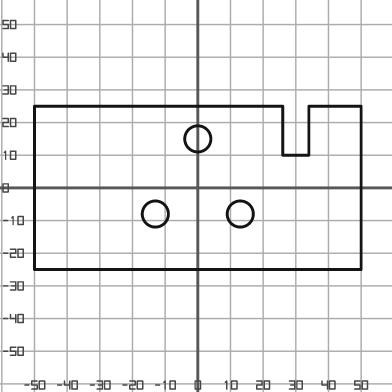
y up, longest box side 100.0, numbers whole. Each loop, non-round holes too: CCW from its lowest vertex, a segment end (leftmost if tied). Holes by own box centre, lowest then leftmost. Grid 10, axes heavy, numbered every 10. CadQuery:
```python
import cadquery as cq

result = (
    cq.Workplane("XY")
    .moveTo(-50.0, -25.0)
    .lineTo(50.0, -25.0)
    .lineTo(50.0, 25.0)
    .lineTo(34.0, 25.0)
    .lineTo(34.0, 10.0)
    .lineTo(26.0, 10.0)
    .lineTo(26.0, 25.0)
    .lineTo(-50.0, 25.0)
    .close()
    .moveTo(-13.0, -8.0)
    .circle(4.0)
    .moveTo(13.0, -8.0)
    .circle(4.0)
    .moveTo(0.0, 15.0)
    .circle(4.0)
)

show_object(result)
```